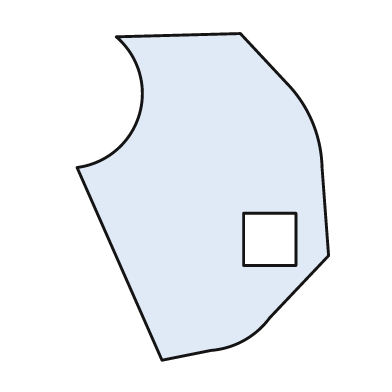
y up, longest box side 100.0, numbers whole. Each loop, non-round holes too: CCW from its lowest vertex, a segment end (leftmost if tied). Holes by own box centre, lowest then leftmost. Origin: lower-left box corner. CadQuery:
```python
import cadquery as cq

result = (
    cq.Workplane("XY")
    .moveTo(26.0, 0.0)
    .lineTo(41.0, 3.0)
    .threePointArc((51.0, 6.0), (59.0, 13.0))
    .lineTo(77.0, 32.0)
    .lineTo(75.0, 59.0)
    .threePointArc((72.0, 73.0), (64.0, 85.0))
    .lineTo(50.0, 100.0)
    .lineTo(12.0, 99.0)
    .threePointArc((19.0, 75.0), (0.0, 59.0))
    .close()
    .moveTo(51.0, 29.0)
    .lineTo(67.0, 29.0)
    .lineTo(67.0, 45.0)
    .lineTo(51.0, 45.0)
    .close()
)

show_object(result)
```